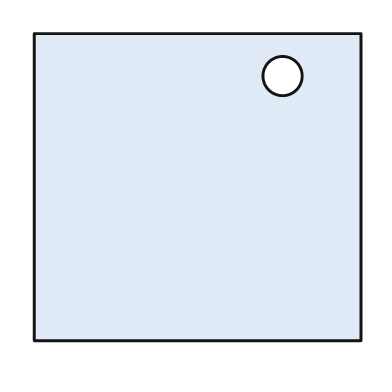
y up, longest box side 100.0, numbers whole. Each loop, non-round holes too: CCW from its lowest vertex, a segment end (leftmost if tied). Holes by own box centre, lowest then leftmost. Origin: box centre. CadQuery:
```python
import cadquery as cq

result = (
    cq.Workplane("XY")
    .moveTo(-50.0, -47.0)
    .lineTo(50.0, -47.0)
    .lineTo(50.0, 47.0)
    .lineTo(-50.0, 47.0)
    .close()
    .moveTo(26.0, 34.0)
    .circle(6.0)
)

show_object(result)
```